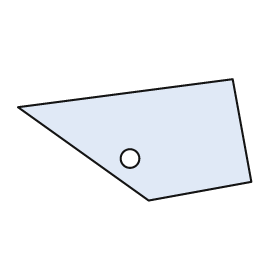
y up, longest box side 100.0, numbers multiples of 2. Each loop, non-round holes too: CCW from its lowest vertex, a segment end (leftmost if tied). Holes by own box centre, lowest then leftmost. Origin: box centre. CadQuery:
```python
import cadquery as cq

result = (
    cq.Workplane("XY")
    .moveTo(6.0, -26.0)
    .lineTo(50.0, -18.0)
    .lineTo(42.0, 26.0)
    .lineTo(-50.0, 14.0)
    .close()
    .moveTo(-2.0, -8.0)
    .circle(4.0)
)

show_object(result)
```